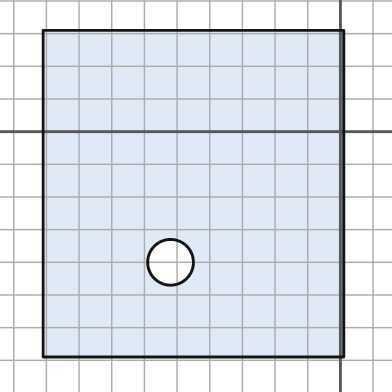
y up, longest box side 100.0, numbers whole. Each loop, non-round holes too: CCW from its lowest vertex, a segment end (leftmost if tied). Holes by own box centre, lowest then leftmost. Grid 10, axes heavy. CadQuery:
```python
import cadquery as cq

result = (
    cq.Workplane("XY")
    .moveTo(-91.0, -69.0)
    .lineTo(1.0, -69.0)
    .lineTo(1.0, 31.0)
    .lineTo(-91.0, 31.0)
    .close()
    .moveTo(-52.0, -40.0)
    .circle(7.0)
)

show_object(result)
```